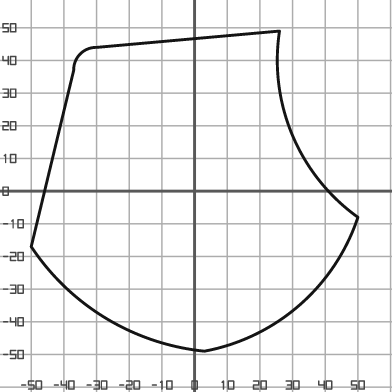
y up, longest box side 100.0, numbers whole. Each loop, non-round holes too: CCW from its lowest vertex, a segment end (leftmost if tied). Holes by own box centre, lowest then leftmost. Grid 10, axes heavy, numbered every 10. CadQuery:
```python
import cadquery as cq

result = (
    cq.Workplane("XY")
    .moveTo(3.0, -49.0)
    .threePointArc((32.0, -35.0), (50.0, -8.0))
    .threePointArc((30.0, 17.0), (26.0, 49.0))
    .lineTo(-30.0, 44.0)
    .threePointArc((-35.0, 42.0), (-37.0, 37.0))
    .lineTo(-50.0, -17.0)
    .threePointArc((-27.0, -39.0), (3.0, -49.0))
    .close()
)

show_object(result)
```